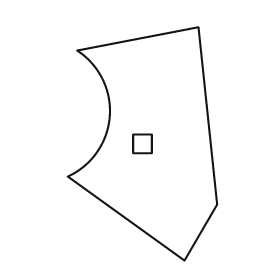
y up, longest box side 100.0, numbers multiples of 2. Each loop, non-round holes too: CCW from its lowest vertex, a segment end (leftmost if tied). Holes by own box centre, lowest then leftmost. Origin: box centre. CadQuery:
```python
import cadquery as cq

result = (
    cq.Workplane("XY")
    .moveTo(18.0, -50.0)
    .lineTo(32.0, -26.0)
    .lineTo(24.0, 50.0)
    .lineTo(-28.0, 40.0)
    .threePointArc((-14.0, 12.0), (-32.0, -14.0))
    .close()
    .moveTo(-4.0, -4.0)
    .lineTo(4.0, -4.0)
    .lineTo(4.0, 4.0)
    .lineTo(-4.0, 4.0)
    .close()
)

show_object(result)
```